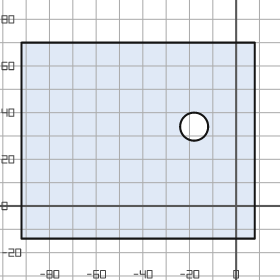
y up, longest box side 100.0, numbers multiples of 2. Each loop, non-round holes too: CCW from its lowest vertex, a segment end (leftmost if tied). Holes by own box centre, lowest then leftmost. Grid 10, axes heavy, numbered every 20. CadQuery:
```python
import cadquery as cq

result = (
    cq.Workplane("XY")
    .moveTo(-92.0, -14.0)
    .lineTo(8.0, -14.0)
    .lineTo(8.0, 70.0)
    .lineTo(-92.0, 70.0)
    .close()
    .moveTo(-18.0, 34.0)
    .circle(6.0)
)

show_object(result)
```